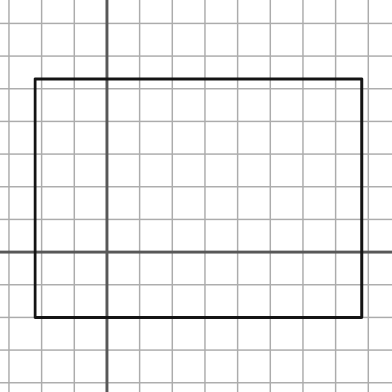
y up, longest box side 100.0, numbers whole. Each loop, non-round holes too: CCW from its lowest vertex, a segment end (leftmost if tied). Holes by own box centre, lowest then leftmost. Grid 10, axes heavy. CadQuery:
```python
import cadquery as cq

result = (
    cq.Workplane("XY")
    .moveTo(-22.0, -20.0)
    .lineTo(78.0, -20.0)
    .lineTo(78.0, 53.0)
    .lineTo(-22.0, 53.0)
    .close()
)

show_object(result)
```